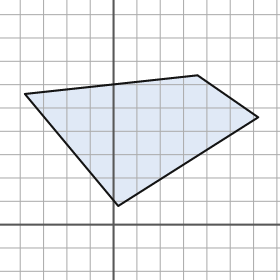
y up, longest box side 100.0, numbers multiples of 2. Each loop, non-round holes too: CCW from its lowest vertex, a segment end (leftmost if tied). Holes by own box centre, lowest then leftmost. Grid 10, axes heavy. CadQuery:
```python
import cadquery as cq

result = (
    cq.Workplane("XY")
    .moveTo(2.0, 8.0)
    .lineTo(62.0, 46.0)
    .lineTo(36.0, 64.0)
    .lineTo(-38.0, 56.0)
    .close()
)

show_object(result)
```